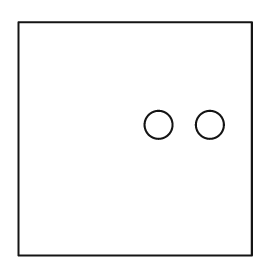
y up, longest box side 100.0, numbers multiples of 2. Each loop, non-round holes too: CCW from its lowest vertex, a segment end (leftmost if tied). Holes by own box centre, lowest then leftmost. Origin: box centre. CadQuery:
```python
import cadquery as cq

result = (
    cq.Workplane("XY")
    .moveTo(-50.0, -50.0)
    .lineTo(50.0, -50.0)
    .lineTo(50.0, 50.0)
    .lineTo(-50.0, 50.0)
    .close()
    .moveTo(10.0, 6.0)
    .circle(6.0)
    .moveTo(32.0, 6.0)
    .circle(6.0)
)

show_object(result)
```